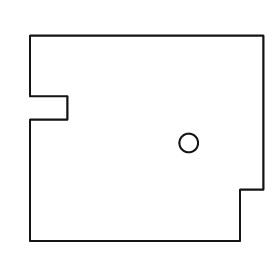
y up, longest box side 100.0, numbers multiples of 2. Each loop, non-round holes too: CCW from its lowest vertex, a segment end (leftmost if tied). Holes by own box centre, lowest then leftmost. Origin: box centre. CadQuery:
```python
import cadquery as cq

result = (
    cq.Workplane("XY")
    .moveTo(-50.0, -44.0)
    .lineTo(40.0, -44.0)
    .lineTo(40.0, -22.0)
    .lineTo(50.0, -22.0)
    .lineTo(50.0, 44.0)
    .lineTo(-50.0, 44.0)
    .lineTo(-50.0, 18.0)
    .lineTo(-34.0, 18.0)
    .lineTo(-34.0, 8.0)
    .lineTo(-50.0, 8.0)
    .close()
    .moveTo(18.0, -2.0)
    .circle(4.0)
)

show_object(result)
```